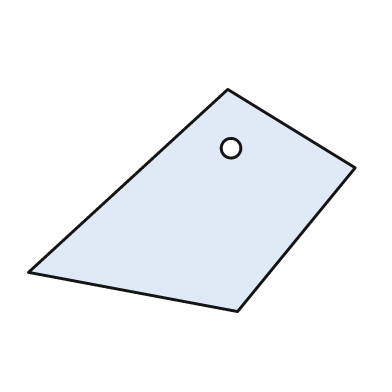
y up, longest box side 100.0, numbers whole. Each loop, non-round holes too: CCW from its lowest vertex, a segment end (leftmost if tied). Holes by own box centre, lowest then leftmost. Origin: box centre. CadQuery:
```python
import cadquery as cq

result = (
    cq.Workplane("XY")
    .moveTo(14.0, -34.0)
    .lineTo(50.0, 10.0)
    .lineTo(11.0, 34.0)
    .lineTo(-50.0, -22.0)
    .close()
    .moveTo(12.0, 16.0)
    .circle(3.0)
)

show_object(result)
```